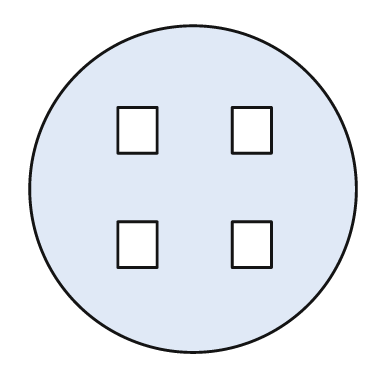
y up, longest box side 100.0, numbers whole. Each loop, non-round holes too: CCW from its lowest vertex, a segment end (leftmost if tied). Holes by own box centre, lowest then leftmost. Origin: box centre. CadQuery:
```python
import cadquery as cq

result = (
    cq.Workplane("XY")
    .moveTo(0.0, 0.0)
    .circle(50.0)
    .moveTo(-23.0, -24.0)
    .lineTo(-11.0, -24.0)
    .lineTo(-11.0, -10.0)
    .lineTo(-23.0, -10.0)
    .close()
    .moveTo(12.0, -24.0)
    .lineTo(24.0, -24.0)
    .lineTo(24.0, -10.0)
    .lineTo(12.0, -10.0)
    .close()
    .moveTo(-23.0, 11.0)
    .lineTo(-11.0, 11.0)
    .lineTo(-11.0, 25.0)
    .lineTo(-23.0, 25.0)
    .close()
    .moveTo(12.0, 11.0)
    .lineTo(24.0, 11.0)
    .lineTo(24.0, 25.0)
    .lineTo(12.0, 25.0)
    .close()
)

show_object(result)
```